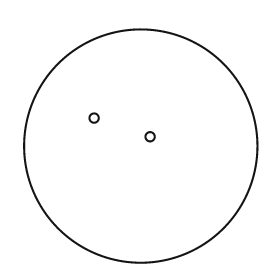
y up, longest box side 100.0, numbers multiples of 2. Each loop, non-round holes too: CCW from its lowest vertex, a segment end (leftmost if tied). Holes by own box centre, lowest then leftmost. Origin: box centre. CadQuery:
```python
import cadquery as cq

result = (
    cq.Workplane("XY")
    .moveTo(0.0, 0.0)
    .circle(50.0)
    .moveTo(4.0, 4.0)
    .circle(2.0)
    .moveTo(-20.0, 12.0)
    .circle(2.0)
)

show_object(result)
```